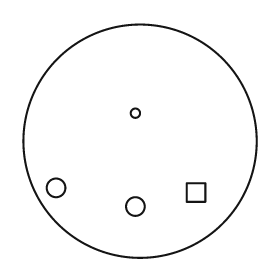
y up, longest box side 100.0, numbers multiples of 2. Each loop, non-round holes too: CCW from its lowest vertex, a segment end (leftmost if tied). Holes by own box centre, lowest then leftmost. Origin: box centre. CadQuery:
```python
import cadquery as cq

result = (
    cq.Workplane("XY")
    .moveTo(0.0, 0.0)
    .circle(50.0)
    .moveTo(-2.0, -28.0)
    .circle(4.0)
    .moveTo(20.0, -26.0)
    .lineTo(28.0, -26.0)
    .lineTo(28.0, -18.0)
    .lineTo(20.0, -18.0)
    .close()
    .moveTo(-36.0, -20.0)
    .circle(4.0)
    .moveTo(-2.0, 12.0)
    .circle(2.0)
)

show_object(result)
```